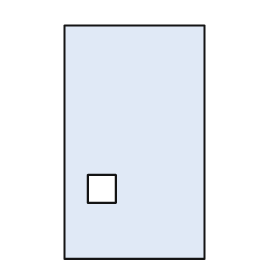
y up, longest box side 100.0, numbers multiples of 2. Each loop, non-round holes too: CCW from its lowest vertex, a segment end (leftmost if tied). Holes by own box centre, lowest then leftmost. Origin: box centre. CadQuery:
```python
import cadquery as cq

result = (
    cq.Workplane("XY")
    .moveTo(-30.0, -50.0)
    .lineTo(30.0, -50.0)
    .lineTo(30.0, 50.0)
    .lineTo(-30.0, 50.0)
    .close()
    .moveTo(-20.0, -26.0)
    .lineTo(-8.0, -26.0)
    .lineTo(-8.0, -14.0)
    .lineTo(-20.0, -14.0)
    .close()
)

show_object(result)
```